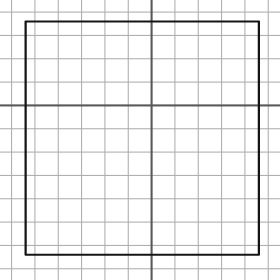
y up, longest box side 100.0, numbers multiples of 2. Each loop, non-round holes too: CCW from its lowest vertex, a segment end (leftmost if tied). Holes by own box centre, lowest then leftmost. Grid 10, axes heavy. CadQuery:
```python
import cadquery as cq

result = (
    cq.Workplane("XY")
    .moveTo(-54.0, -64.0)
    .lineTo(46.0, -64.0)
    .lineTo(46.0, 36.0)
    .lineTo(-54.0, 36.0)
    .close()
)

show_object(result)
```